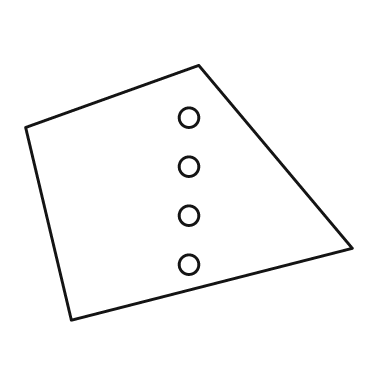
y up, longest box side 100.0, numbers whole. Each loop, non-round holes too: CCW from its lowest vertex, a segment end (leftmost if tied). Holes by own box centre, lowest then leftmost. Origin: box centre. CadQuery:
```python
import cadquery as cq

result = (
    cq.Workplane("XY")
    .moveTo(-36.0, -39.0)
    .lineTo(50.0, -17.0)
    .lineTo(3.0, 39.0)
    .lineTo(-50.0, 20.0)
    .close()
    .moveTo(0.0, -22.0)
    .circle(3.0)
    .moveTo(0.0, -7.0)
    .circle(3.0)
    .moveTo(0.0, 8.0)
    .circle(3.0)
    .moveTo(0.0, 23.0)
    .circle(3.0)
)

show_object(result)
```